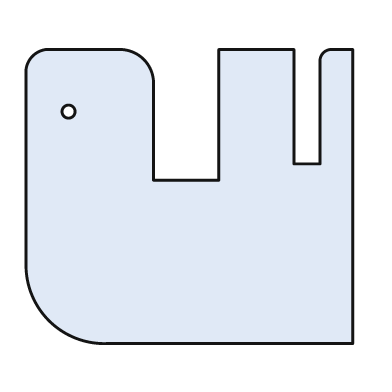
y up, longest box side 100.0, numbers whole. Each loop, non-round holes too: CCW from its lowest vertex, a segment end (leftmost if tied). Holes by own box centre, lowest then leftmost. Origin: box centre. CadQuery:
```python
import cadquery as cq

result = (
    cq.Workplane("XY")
    .moveTo(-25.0, -45.0)
    .lineTo(50.0, -45.0)
    .lineTo(50.0, 45.0)
    .lineTo(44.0, 45.0)
    .threePointArc((41.0, 44.0), (40.0, 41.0))
    .lineTo(40.0, 10.0)
    .lineTo(32.0, 10.0)
    .lineTo(32.0, 45.0)
    .lineTo(9.0, 45.0)
    .lineTo(9.0, 5.0)
    .lineTo(-11.0, 5.0)
    .lineTo(-11.0, 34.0)
    .threePointArc((-14.0, 42.0), (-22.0, 45.0))
    .lineTo(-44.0, 45.0)
    .threePointArc((-48.0, 43.0), (-50.0, 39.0))
    .lineTo(-50.0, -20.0)
    .threePointArc((-43.0, -38.0), (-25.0, -45.0))
    .close()
    .moveTo(-37.0, 26.0)
    .circle(2.0)
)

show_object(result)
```